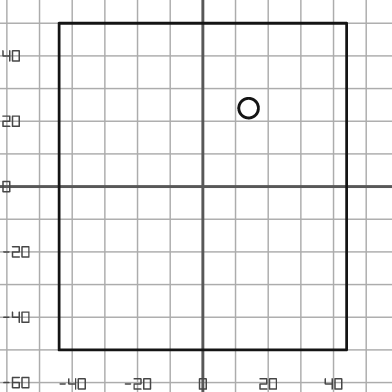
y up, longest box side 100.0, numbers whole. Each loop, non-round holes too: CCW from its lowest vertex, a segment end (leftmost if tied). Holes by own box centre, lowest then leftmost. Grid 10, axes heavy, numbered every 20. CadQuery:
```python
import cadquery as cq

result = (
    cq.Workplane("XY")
    .moveTo(-44.0, -50.0)
    .lineTo(44.0, -50.0)
    .lineTo(44.0, 50.0)
    .lineTo(-44.0, 50.0)
    .close()
    .moveTo(14.0, 24.0)
    .circle(3.0)
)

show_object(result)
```